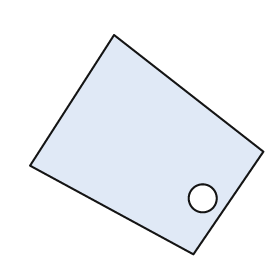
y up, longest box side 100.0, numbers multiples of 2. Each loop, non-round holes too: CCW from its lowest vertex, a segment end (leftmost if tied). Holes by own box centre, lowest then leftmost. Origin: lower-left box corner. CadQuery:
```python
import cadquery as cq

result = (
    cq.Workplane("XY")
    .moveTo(70.0, 0.0)
    .lineTo(100.0, 44.0)
    .lineTo(36.0, 94.0)
    .lineTo(0.0, 38.0)
    .close()
    .moveTo(74.0, 24.0)
    .circle(6.0)
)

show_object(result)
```